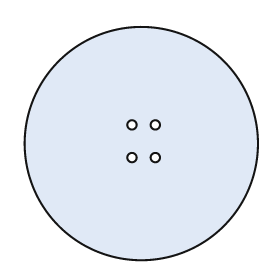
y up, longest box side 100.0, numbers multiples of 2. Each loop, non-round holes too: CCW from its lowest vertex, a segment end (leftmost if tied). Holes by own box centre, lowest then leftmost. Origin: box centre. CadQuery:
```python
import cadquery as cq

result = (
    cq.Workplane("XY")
    .moveTo(0.0, 0.0)
    .circle(50.0)
    .moveTo(-4.0, -6.0)
    .circle(2.0)
    .moveTo(6.0, -6.0)
    .circle(2.0)
    .moveTo(-4.0, 8.0)
    .circle(2.0)
    .moveTo(6.0, 8.0)
    .circle(2.0)
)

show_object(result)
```